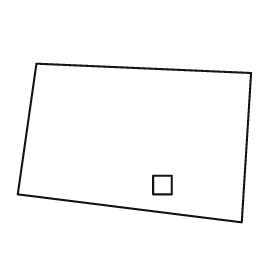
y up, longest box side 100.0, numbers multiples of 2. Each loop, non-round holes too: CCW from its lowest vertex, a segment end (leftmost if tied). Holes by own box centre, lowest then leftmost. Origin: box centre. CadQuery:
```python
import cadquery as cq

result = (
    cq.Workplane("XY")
    .moveTo(46.0, -34.0)
    .lineTo(50.0, 30.0)
    .lineTo(-42.0, 34.0)
    .lineTo(-50.0, -22.0)
    .close()
    .moveTo(8.0, -22.0)
    .lineTo(16.0, -22.0)
    .lineTo(16.0, -14.0)
    .lineTo(8.0, -14.0)
    .close()
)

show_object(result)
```